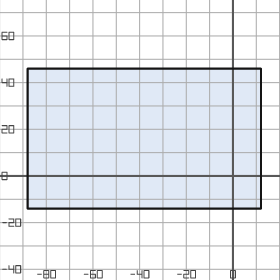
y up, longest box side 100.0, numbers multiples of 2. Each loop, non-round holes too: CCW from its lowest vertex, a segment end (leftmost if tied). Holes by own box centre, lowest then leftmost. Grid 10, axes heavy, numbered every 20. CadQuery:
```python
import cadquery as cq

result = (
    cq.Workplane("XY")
    .moveTo(-88.0, -14.0)
    .lineTo(12.0, -14.0)
    .lineTo(12.0, 46.0)
    .lineTo(-88.0, 46.0)
    .close()
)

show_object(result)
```